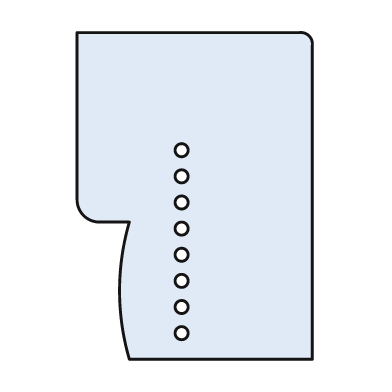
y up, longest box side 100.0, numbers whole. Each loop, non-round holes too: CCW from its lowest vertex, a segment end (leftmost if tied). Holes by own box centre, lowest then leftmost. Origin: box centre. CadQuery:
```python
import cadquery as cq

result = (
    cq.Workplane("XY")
    .moveTo(-20.0, -50.0)
    .lineTo(36.0, -50.0)
    .lineTo(36.0, 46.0)
    .threePointArc((35.0, 49.0), (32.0, 50.0))
    .lineTo(-36.0, 50.0)
    .lineTo(-36.0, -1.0)
    .threePointArc((-34.0, -6.0), (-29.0, -8.0))
    .lineTo(-20.0, -8.0)
    .threePointArc((-23.0, -29.0), (-20.0, -50.0))
    .close()
    .moveTo(-4.0, -42.0)
    .circle(2.0)
    .moveTo(-4.0, -34.0)
    .circle(2.0)
    .moveTo(-4.0, -26.0)
    .circle(2.0)
    .moveTo(-4.0, -18.0)
    .circle(2.0)
    .moveTo(-4.0, -10.0)
    .circle(2.0)
    .moveTo(-4.0, -2.0)
    .circle(2.0)
    .moveTo(-4.0, 6.0)
    .circle(2.0)
    .moveTo(-4.0, 14.0)
    .circle(2.0)
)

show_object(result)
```